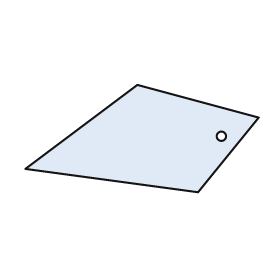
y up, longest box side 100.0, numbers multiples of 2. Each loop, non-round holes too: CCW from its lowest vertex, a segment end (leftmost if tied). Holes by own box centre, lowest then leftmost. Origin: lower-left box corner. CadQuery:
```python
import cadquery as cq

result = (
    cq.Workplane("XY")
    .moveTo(74.0, 0.0)
    .lineTo(100.0, 32.0)
    .lineTo(48.0, 46.0)
    .lineTo(0.0, 10.0)
    .close()
    .moveTo(84.0, 24.0)
    .circle(2.0)
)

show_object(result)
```